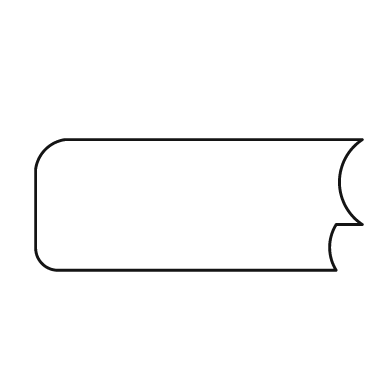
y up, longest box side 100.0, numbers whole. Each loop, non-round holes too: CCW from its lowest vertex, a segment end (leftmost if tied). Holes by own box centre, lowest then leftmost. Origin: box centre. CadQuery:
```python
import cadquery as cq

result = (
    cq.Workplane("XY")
    .moveTo(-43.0, -20.0)
    .lineTo(42.0, -20.0)
    .threePointArc((40.0, -13.0), (42.0, -6.0))
    .lineTo(50.0, -6.0)
    .threePointArc((43.0, 7.0), (50.0, 20.0))
    .lineTo(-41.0, 20.0)
    .threePointArc((-47.0, 17.0), (-50.0, 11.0))
    .lineTo(-50.0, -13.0)
    .threePointArc((-48.0, -18.0), (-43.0, -20.0))
    .close()
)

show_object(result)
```